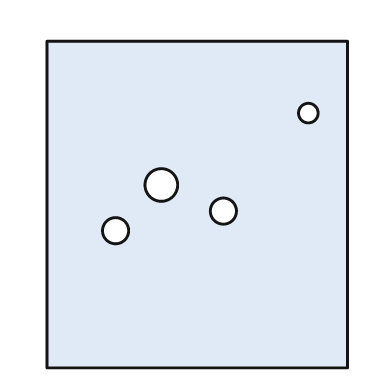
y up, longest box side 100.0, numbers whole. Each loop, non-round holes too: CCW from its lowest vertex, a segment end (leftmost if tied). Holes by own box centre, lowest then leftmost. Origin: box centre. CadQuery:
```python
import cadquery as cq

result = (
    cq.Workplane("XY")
    .moveTo(-46.0, -50.0)
    .lineTo(46.0, -50.0)
    .lineTo(46.0, 50.0)
    .lineTo(-46.0, 50.0)
    .close()
    .moveTo(-25.0, -8.0)
    .circle(4.0)
    .moveTo(8.0, -2.0)
    .circle(4.0)
    .moveTo(-11.0, 6.0)
    .circle(5.0)
    .moveTo(34.0, 28.0)
    .circle(3.0)
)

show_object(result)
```